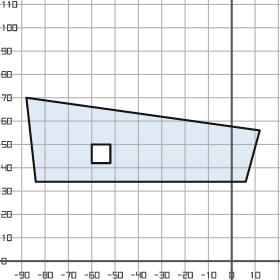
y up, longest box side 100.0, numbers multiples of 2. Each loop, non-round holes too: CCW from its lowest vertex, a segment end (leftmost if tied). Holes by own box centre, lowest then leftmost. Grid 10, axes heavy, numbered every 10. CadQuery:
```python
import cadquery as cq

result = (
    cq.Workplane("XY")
    .moveTo(-84.0, 34.0)
    .lineTo(6.0, 34.0)
    .lineTo(12.0, 56.0)
    .lineTo(-88.0, 70.0)
    .close()
    .moveTo(-60.0, 42.0)
    .lineTo(-52.0, 42.0)
    .lineTo(-52.0, 50.0)
    .lineTo(-60.0, 50.0)
    .close()
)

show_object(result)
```